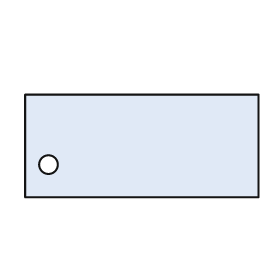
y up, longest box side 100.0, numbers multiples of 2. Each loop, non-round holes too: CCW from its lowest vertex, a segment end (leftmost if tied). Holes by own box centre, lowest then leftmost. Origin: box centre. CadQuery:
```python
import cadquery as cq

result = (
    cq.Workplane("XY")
    .moveTo(-50.0, -22.0)
    .lineTo(50.0, -22.0)
    .lineTo(50.0, 22.0)
    .lineTo(-50.0, 22.0)
    .close()
    .moveTo(-40.0, -8.0)
    .circle(4.0)
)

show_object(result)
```